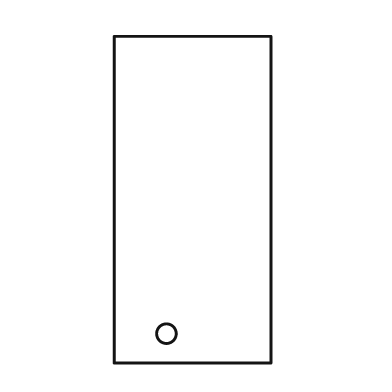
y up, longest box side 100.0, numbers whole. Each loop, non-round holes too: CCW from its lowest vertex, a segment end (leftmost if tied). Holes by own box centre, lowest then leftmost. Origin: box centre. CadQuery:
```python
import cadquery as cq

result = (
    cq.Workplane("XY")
    .moveTo(-24.0, -50.0)
    .lineTo(24.0, -50.0)
    .lineTo(24.0, 50.0)
    .lineTo(-24.0, 50.0)
    .close()
    .moveTo(-8.0, -41.0)
    .circle(3.0)
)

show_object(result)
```